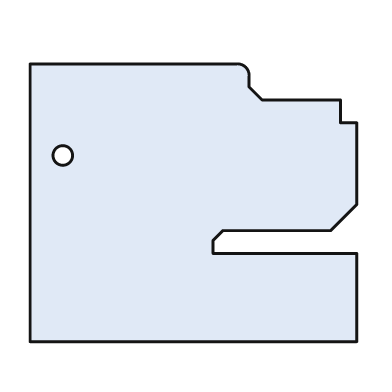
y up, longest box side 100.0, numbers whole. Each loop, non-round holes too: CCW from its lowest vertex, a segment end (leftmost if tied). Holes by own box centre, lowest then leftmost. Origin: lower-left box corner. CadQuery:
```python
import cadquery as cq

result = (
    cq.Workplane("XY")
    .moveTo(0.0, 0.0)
    .lineTo(100.0, 0.0)
    .lineTo(100.0, 27.0)
    .lineTo(56.0, 27.0)
    .lineTo(56.0, 31.0)
    .lineTo(59.0, 34.0)
    .lineTo(92.0, 34.0)
    .lineTo(100.0, 42.0)
    .lineTo(100.0, 67.0)
    .lineTo(95.0, 67.0)
    .lineTo(95.0, 74.0)
    .lineTo(71.0, 74.0)
    .lineTo(67.0, 78.0)
    .lineTo(67.0, 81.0)
    .threePointArc((66.0, 84.0), (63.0, 85.0))
    .lineTo(0.0, 85.0)
    .close()
    .moveTo(10.0, 57.0)
    .circle(3.0)
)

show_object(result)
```